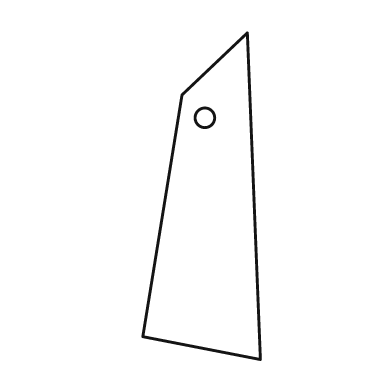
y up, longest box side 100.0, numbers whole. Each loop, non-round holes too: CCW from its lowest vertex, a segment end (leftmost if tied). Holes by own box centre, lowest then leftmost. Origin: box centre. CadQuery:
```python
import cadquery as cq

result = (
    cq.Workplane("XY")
    .moveTo(18.0, -50.0)
    .lineTo(14.0, 50.0)
    .lineTo(-6.0, 31.0)
    .lineTo(-18.0, -43.0)
    .close()
    .moveTo(1.0, 24.0)
    .circle(3.0)
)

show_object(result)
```